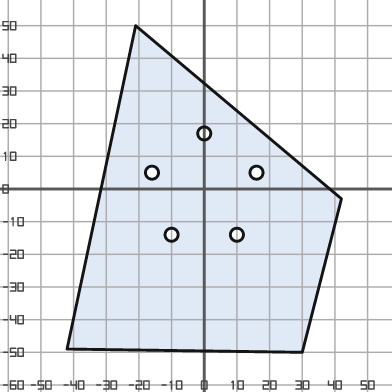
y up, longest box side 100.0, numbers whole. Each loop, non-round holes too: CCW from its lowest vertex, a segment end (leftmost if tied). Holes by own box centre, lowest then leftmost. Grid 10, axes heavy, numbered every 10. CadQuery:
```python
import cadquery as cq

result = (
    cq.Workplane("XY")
    .moveTo(30.0, -50.0)
    .lineTo(42.0, -3.0)
    .lineTo(-21.0, 50.0)
    .lineTo(-42.0, -49.0)
    .close()
    .moveTo(-10.0, -14.0)
    .circle(2.0)
    .moveTo(10.0, -14.0)
    .circle(2.0)
    .moveTo(-16.0, 5.0)
    .circle(2.0)
    .moveTo(16.0, 5.0)
    .circle(2.0)
    .moveTo(0.0, 17.0)
    .circle(2.0)
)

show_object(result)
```